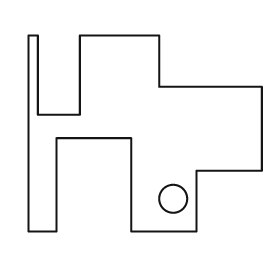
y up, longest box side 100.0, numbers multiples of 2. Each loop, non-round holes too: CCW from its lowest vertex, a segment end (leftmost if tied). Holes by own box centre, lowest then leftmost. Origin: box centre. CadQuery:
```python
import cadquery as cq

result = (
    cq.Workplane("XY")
    .moveTo(-50.0, -42.0)
    .lineTo(-38.0, -42.0)
    .lineTo(-38.0, -2.0)
    .lineTo(-6.0, -2.0)
    .lineTo(-6.0, -42.0)
    .lineTo(22.0, -42.0)
    .lineTo(22.0, -16.0)
    .lineTo(50.0, -16.0)
    .lineTo(50.0, 20.0)
    .lineTo(6.0, 20.0)
    .lineTo(6.0, 42.0)
    .lineTo(-28.0, 42.0)
    .lineTo(-28.0, 8.0)
    .lineTo(-46.0, 8.0)
    .lineTo(-46.0, 42.0)
    .lineTo(-50.0, 42.0)
    .close()
    .moveTo(12.0, -28.0)
    .circle(6.0)
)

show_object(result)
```